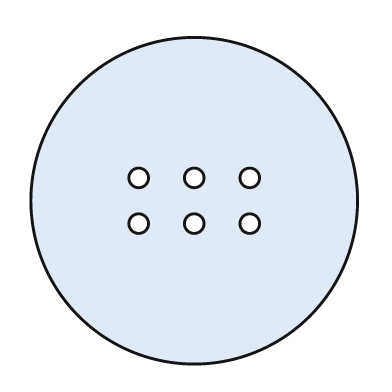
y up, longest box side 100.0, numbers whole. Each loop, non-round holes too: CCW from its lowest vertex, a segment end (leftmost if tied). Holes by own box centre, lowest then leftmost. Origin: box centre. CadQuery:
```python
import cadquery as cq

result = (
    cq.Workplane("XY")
    .moveTo(0.0, 0.0)
    .circle(50.0)
    .moveTo(-17.0, -7.0)
    .circle(3.0)
    .moveTo(0.0, -7.0)
    .circle(3.0)
    .moveTo(17.0, -7.0)
    .circle(3.0)
    .moveTo(-17.0, 7.0)
    .circle(3.0)
    .moveTo(0.0, 7.0)
    .circle(3.0)
    .moveTo(17.0, 7.0)
    .circle(3.0)
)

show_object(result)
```